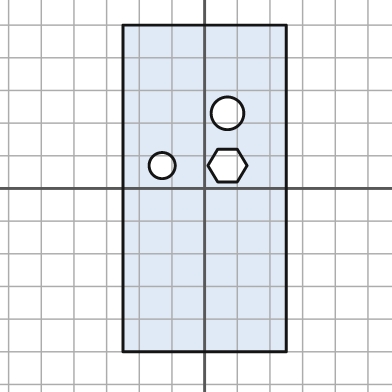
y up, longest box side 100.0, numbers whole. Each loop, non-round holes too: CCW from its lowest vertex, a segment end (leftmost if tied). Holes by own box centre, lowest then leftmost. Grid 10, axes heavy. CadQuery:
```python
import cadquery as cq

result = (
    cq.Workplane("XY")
    .moveTo(-25.0, -50.0)
    .lineTo(25.0, -50.0)
    .lineTo(25.0, 50.0)
    .lineTo(-25.0, 50.0)
    .close()
    .moveTo(-13.0, 7.0)
    .circle(4.0)
    .moveTo(4.0, 2.0)
    .lineTo(10.0, 2.0)
    .lineTo(13.0, 7.0)
    .lineTo(10.0, 12.0)
    .lineTo(4.0, 12.0)
    .lineTo(1.0, 7.0)
    .close()
    .moveTo(7.0, 23.0)
    .circle(5.0)
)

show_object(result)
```